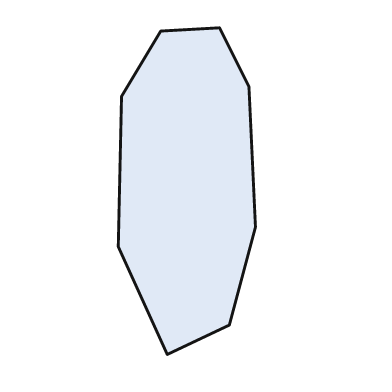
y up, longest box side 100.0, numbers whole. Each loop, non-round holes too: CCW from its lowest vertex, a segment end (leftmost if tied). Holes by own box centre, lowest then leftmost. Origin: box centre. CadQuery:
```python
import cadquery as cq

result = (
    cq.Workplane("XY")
    .moveTo(-6.0, -50.0)
    .lineTo(13.0, -41.0)
    .lineTo(21.0, -11.0)
    .lineTo(19.0, 32.0)
    .lineTo(10.0, 50.0)
    .lineTo(-8.0, 49.0)
    .lineTo(-20.0, 29.0)
    .lineTo(-21.0, -17.0)
    .close()
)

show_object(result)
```